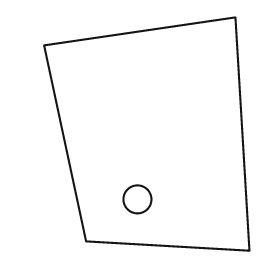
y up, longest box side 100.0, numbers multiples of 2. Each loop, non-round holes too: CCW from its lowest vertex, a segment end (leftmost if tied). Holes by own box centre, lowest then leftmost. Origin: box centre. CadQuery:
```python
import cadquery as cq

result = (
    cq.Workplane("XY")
    .moveTo(44.0, -50.0)
    .lineTo(38.0, 50.0)
    .lineTo(-44.0, 38.0)
    .lineTo(-26.0, -46.0)
    .close()
    .moveTo(-4.0, -28.0)
    .circle(6.0)
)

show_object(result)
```